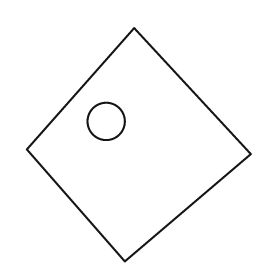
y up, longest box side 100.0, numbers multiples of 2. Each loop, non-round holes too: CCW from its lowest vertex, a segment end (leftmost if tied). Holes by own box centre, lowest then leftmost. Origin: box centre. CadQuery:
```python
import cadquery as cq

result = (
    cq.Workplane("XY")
    .moveTo(-6.0, -50.0)
    .lineTo(48.0, -4.0)
    .lineTo(-2.0, 50.0)
    .lineTo(-48.0, -2.0)
    .close()
    .moveTo(-14.0, 10.0)
    .circle(8.0)
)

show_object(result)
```